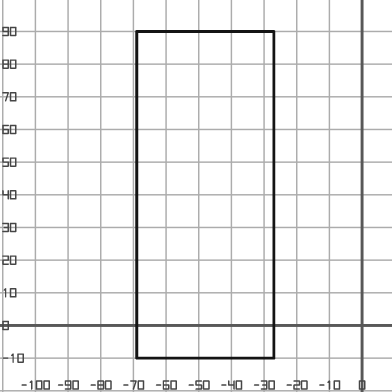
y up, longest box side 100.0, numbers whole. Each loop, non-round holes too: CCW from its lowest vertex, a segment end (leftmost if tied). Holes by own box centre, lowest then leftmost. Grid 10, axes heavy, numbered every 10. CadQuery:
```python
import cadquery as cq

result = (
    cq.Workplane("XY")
    .moveTo(-69.0, -10.0)
    .lineTo(-27.0, -10.0)
    .lineTo(-27.0, 90.0)
    .lineTo(-69.0, 90.0)
    .close()
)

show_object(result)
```